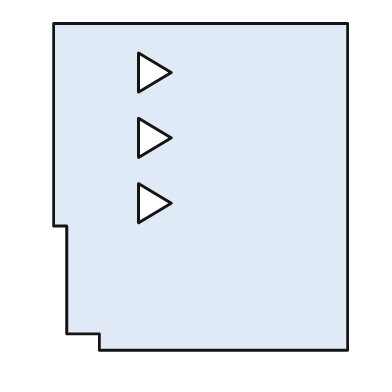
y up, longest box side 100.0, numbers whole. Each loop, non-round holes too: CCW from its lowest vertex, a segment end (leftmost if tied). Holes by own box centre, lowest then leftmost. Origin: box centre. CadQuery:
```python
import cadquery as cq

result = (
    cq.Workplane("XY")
    .moveTo(-31.0, -50.0)
    .lineTo(45.0, -50.0)
    .lineTo(45.0, 50.0)
    .lineTo(-45.0, 50.0)
    .lineTo(-45.0, -12.0)
    .lineTo(-41.0, -12.0)
    .lineTo(-41.0, -45.0)
    .lineTo(-31.0, -45.0)
    .close()
    .moveTo(-19.0, -11.0)
    .lineTo(-9.0, -5.0)
    .lineTo(-19.0, 1.0)
    .close()
    .moveTo(-19.0, 9.0)
    .lineTo(-9.0, 15.0)
    .lineTo(-19.0, 21.0)
    .close()
    .moveTo(-19.0, 29.0)
    .lineTo(-9.0, 35.0)
    .lineTo(-19.0, 41.0)
    .close()
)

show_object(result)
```